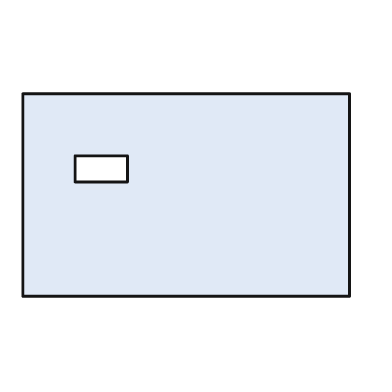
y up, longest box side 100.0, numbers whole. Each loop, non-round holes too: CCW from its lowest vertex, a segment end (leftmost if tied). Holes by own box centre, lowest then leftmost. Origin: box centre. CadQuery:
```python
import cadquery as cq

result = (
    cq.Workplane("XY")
    .moveTo(-50.0, -31.0)
    .lineTo(50.0, -31.0)
    .lineTo(50.0, 31.0)
    .lineTo(-50.0, 31.0)
    .close()
    .moveTo(-34.0, 4.0)
    .lineTo(-18.0, 4.0)
    .lineTo(-18.0, 12.0)
    .lineTo(-34.0, 12.0)
    .close()
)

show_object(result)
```